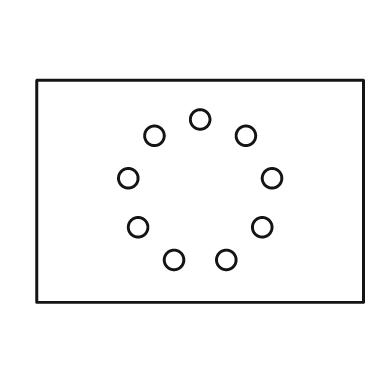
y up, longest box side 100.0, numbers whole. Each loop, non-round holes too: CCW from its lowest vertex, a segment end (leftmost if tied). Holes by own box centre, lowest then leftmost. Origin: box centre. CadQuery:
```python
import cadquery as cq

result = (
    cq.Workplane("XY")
    .moveTo(-50.0, -34.0)
    .lineTo(50.0, -34.0)
    .lineTo(50.0, 34.0)
    .lineTo(-50.0, 34.0)
    .close()
    .moveTo(-8.0, -21.0)
    .circle(3.0)
    .moveTo(8.0, -21.0)
    .circle(3.0)
    .moveTo(-19.0, -11.0)
    .circle(3.0)
    .moveTo(19.0, -11.0)
    .circle(3.0)
    .moveTo(-22.0, 4.0)
    .circle(3.0)
    .moveTo(22.0, 4.0)
    .circle(3.0)
    .moveTo(-14.0, 17.0)
    .circle(3.0)
    .moveTo(14.0, 17.0)
    .circle(3.0)
    .moveTo(0.0, 22.0)
    .circle(3.0)
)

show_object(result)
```